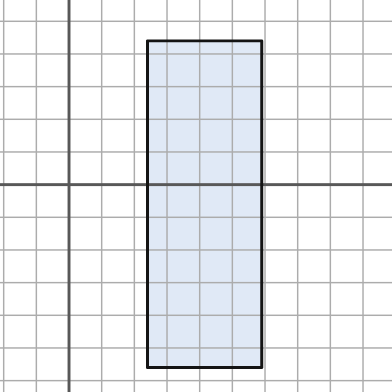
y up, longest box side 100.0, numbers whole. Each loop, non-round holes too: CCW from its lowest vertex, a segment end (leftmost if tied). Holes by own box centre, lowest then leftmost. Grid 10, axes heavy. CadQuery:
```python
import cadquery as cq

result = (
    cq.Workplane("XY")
    .moveTo(24.0, -56.0)
    .lineTo(59.0, -56.0)
    .lineTo(59.0, 44.0)
    .lineTo(24.0, 44.0)
    .close()
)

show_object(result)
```